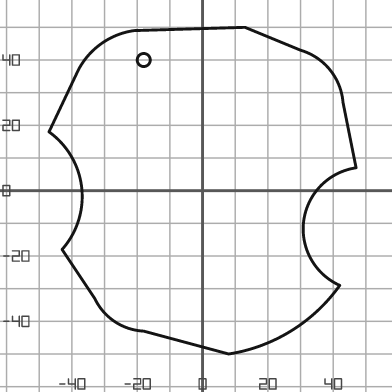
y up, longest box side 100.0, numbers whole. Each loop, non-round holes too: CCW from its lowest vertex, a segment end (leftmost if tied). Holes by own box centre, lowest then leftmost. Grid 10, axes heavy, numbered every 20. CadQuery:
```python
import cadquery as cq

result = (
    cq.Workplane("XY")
    .moveTo(8.0, -50.0)
    .threePointArc((27.0, -43.0), (42.0, -29.0))
    .threePointArc((31.0, -9.0), (47.0, 7.0))
    .lineTo(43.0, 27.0)
    .threePointArc((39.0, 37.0), (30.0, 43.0))
    .lineTo(13.0, 50.0)
    .lineTo(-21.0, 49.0)
    .threePointArc((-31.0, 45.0), (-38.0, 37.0))
    .lineTo(-47.0, 18.0)
    .threePointArc((-37.0, 1.0), (-43.0, -18.0))
    .lineTo(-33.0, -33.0)
    .threePointArc((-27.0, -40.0), (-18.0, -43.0))
    .close()
    .moveTo(-18.0, 40.0)
    .circle(2.0)
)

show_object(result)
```